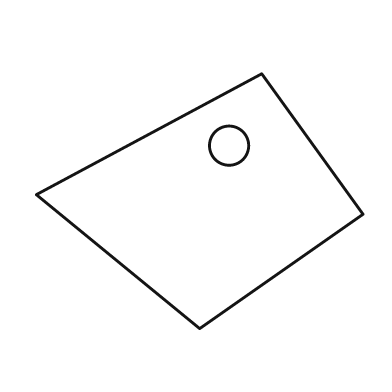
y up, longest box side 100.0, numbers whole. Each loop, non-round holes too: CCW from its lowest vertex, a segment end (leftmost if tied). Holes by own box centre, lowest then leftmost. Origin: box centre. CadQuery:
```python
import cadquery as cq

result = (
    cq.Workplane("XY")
    .moveTo(0.0, -39.0)
    .lineTo(50.0, -4.0)
    .lineTo(19.0, 39.0)
    .lineTo(-50.0, 2.0)
    .close()
    .moveTo(9.0, 17.0)
    .circle(6.0)
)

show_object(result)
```